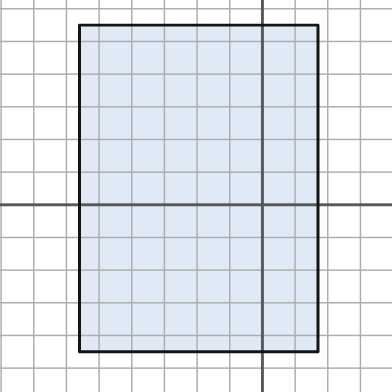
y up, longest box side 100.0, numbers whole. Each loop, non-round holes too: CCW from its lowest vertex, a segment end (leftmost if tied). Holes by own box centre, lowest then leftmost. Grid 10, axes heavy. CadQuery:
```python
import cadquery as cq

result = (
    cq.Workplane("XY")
    .moveTo(-56.0, -45.0)
    .lineTo(17.0, -45.0)
    .lineTo(17.0, 55.0)
    .lineTo(-56.0, 55.0)
    .close()
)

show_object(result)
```